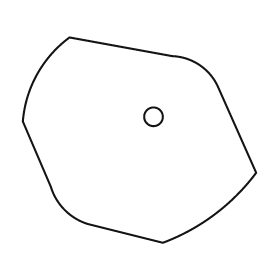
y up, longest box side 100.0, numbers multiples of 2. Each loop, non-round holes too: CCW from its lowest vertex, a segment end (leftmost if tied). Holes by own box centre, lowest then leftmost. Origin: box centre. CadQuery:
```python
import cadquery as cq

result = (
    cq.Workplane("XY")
    .moveTo(10.0, -44.0)
    .threePointArc((32.0, -32.0), (50.0, -14.0))
    .lineTo(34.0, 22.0)
    .threePointArc((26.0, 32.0), (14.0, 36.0))
    .lineTo(-30.0, 44.0)
    .threePointArc((-44.0, 28.0), (-50.0, 8.0))
    .lineTo(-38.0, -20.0)
    .threePointArc((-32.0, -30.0), (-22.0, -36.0))
    .close()
    .moveTo(6.0, 10.0)
    .circle(4.0)
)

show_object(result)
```